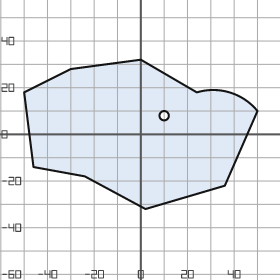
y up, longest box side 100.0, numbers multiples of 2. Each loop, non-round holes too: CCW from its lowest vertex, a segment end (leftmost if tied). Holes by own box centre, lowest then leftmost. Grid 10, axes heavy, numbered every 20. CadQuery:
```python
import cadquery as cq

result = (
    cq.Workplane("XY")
    .moveTo(2.0, -32.0)
    .lineTo(36.0, -22.0)
    .lineTo(50.0, 10.0)
    .threePointArc((38.0, 18.0), (24.0, 18.0))
    .lineTo(0.0, 32.0)
    .lineTo(-30.0, 28.0)
    .lineTo(-50.0, 18.0)
    .lineTo(-46.0, -14.0)
    .lineTo(-24.0, -18.0)
    .close()
    .moveTo(10.0, 8.0)
    .circle(2.0)
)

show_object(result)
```